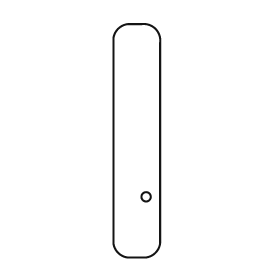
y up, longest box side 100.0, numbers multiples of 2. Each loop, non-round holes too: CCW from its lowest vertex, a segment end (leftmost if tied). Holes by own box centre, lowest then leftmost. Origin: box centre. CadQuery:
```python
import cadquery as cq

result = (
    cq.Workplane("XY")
    .moveTo(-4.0, -50.0)
    .lineTo(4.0, -50.0)
    .threePointArc((8.0, -48.0), (10.0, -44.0))
    .lineTo(10.0, 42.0)
    .threePointArc((8.0, 48.0), (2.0, 50.0))
    .lineTo(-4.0, 50.0)
    .threePointArc((-8.0, 48.0), (-10.0, 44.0))
    .lineTo(-10.0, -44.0)
    .threePointArc((-8.0, -48.0), (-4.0, -50.0))
    .close()
    .moveTo(4.0, -24.0)
    .circle(2.0)
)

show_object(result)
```